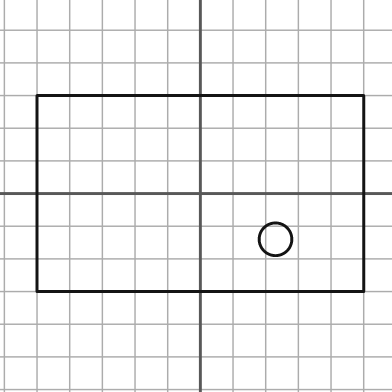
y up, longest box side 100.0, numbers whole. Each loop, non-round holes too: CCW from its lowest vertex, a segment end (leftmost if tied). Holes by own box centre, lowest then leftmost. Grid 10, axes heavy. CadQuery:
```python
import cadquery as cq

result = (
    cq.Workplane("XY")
    .moveTo(-50.0, -30.0)
    .lineTo(50.0, -30.0)
    .lineTo(50.0, 30.0)
    .lineTo(-50.0, 30.0)
    .close()
    .moveTo(23.0, -14.0)
    .circle(5.0)
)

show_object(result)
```